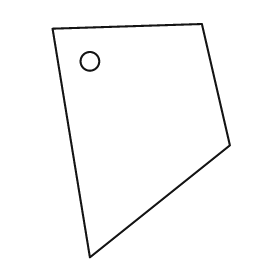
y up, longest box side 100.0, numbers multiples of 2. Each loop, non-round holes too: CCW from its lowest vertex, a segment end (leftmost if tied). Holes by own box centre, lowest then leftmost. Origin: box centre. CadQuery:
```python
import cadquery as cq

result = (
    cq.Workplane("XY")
    .moveTo(-22.0, -50.0)
    .lineTo(38.0, -2.0)
    .lineTo(26.0, 50.0)
    .lineTo(-38.0, 48.0)
    .close()
    .moveTo(-22.0, 34.0)
    .circle(4.0)
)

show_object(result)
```